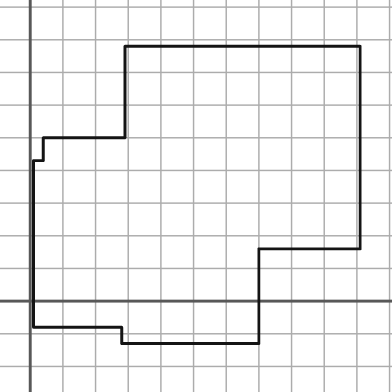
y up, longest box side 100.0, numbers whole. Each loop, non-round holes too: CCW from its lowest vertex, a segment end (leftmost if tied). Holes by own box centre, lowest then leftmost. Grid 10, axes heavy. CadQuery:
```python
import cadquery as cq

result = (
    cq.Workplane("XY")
    .moveTo(28.0, -13.0)
    .lineTo(70.0, -13.0)
    .lineTo(70.0, 16.0)
    .lineTo(101.0, 16.0)
    .lineTo(101.0, 78.0)
    .lineTo(29.0, 78.0)
    .lineTo(29.0, 50.0)
    .lineTo(4.0, 50.0)
    .lineTo(4.0, 43.0)
    .lineTo(1.0, 43.0)
    .lineTo(1.0, -8.0)
    .lineTo(28.0, -8.0)
    .close()
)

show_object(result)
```